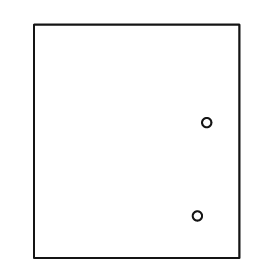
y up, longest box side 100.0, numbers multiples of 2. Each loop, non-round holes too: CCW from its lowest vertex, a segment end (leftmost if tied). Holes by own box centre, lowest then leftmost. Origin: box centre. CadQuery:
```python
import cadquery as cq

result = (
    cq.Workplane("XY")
    .moveTo(-44.0, -50.0)
    .lineTo(44.0, -50.0)
    .lineTo(44.0, 50.0)
    .lineTo(-44.0, 50.0)
    .close()
    .moveTo(26.0, -32.0)
    .circle(2.0)
    .moveTo(30.0, 8.0)
    .circle(2.0)
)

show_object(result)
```